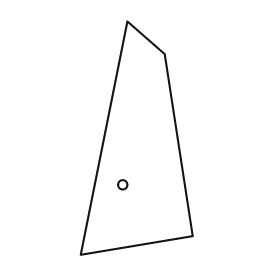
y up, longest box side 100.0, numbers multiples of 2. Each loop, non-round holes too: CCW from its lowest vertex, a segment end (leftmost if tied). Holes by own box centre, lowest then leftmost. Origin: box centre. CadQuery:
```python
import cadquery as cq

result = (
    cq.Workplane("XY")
    .moveTo(-24.0, -50.0)
    .lineTo(24.0, -42.0)
    .lineTo(12.0, 36.0)
    .lineTo(-4.0, 50.0)
    .close()
    .moveTo(-6.0, -20.0)
    .circle(2.0)
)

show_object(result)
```